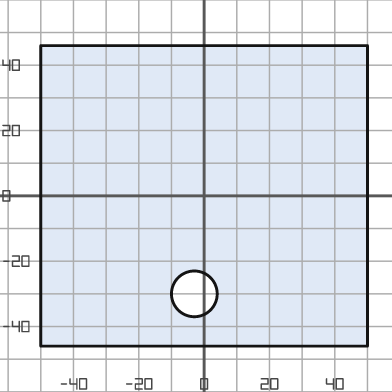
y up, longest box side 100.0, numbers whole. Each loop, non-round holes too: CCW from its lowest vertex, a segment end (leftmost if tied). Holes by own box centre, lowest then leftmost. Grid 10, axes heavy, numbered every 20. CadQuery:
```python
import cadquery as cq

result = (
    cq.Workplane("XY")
    .moveTo(-50.0, -46.0)
    .lineTo(50.0, -46.0)
    .lineTo(50.0, 46.0)
    .lineTo(-50.0, 46.0)
    .close()
    .moveTo(-3.0, -30.0)
    .circle(7.0)
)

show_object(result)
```